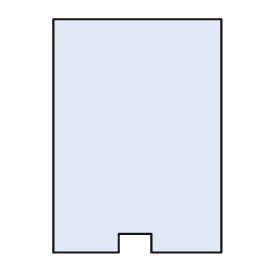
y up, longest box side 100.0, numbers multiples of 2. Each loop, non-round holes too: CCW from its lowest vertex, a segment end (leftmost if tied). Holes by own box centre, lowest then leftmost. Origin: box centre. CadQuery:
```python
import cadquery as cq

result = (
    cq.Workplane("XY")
    .moveTo(-36.0, -50.0)
    .lineTo(-8.0, -50.0)
    .lineTo(-8.0, -42.0)
    .lineTo(6.0, -42.0)
    .lineTo(6.0, -50.0)
    .lineTo(36.0, -50.0)
    .lineTo(36.0, 50.0)
    .lineTo(-36.0, 50.0)
    .close()
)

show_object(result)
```